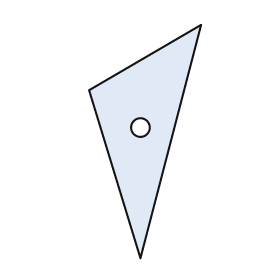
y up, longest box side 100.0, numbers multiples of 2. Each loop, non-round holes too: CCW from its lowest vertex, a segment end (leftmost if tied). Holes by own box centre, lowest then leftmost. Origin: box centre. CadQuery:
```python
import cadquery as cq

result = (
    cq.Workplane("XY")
    .moveTo(-2.0, -50.0)
    .lineTo(24.0, 50.0)
    .lineTo(-24.0, 22.0)
    .close()
    .moveTo(-2.0, 6.0)
    .circle(4.0)
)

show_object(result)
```